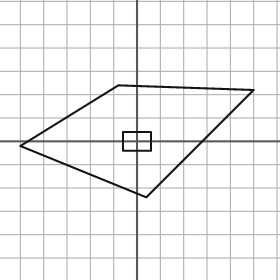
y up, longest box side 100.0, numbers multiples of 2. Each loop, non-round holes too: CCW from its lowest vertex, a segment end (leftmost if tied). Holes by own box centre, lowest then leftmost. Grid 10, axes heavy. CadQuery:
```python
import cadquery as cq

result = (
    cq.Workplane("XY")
    .moveTo(4.0, -24.0)
    .lineTo(50.0, 22.0)
    .lineTo(-8.0, 24.0)
    .lineTo(-50.0, -2.0)
    .close()
    .moveTo(-6.0, -4.0)
    .lineTo(6.0, -4.0)
    .lineTo(6.0, 4.0)
    .lineTo(-6.0, 4.0)
    .close()
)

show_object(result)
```